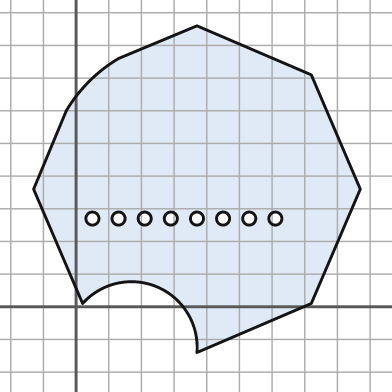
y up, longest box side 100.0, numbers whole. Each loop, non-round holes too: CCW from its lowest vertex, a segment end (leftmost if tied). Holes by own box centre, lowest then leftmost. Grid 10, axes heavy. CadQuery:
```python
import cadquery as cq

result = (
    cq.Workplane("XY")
    .moveTo(37.0, -14.0)
    .lineTo(72.0, 1.0)
    .lineTo(87.0, 36.0)
    .lineTo(72.0, 71.0)
    .lineTo(37.0, 86.0)
    .lineTo(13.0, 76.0)
    .threePointArc((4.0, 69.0), (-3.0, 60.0))
    .lineTo(-13.0, 36.0)
    .lineTo(2.0, 1.0)
    .threePointArc((25.0, 6.0), (37.0, -14.0))
    .close()
    .moveTo(5.0, 27.0)
    .circle(2.0)
    .moveTo(13.0, 27.0)
    .circle(2.0)
    .moveTo(21.0, 27.0)
    .circle(2.0)
    .moveTo(29.0, 27.0)
    .circle(2.0)
    .moveTo(37.0, 27.0)
    .circle(2.0)
    .moveTo(45.0, 27.0)
    .circle(2.0)
    .moveTo(53.0, 27.0)
    .circle(2.0)
    .moveTo(61.0, 27.0)
    .circle(2.0)
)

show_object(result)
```